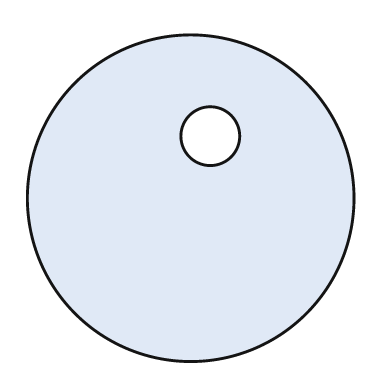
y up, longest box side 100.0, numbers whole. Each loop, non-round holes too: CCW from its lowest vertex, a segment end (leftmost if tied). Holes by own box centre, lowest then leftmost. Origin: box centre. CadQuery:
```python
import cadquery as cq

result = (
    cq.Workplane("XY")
    .moveTo(0.0, 0.0)
    .circle(50.0)
    .moveTo(6.0, 19.0)
    .circle(9.0)
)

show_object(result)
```